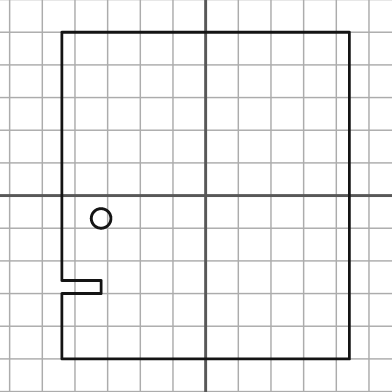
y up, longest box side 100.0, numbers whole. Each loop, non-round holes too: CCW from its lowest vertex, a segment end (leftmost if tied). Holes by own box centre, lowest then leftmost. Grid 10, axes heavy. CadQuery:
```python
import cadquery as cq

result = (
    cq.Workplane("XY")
    .moveTo(-44.0, -50.0)
    .lineTo(44.0, -50.0)
    .lineTo(44.0, 50.0)
    .lineTo(-44.0, 50.0)
    .lineTo(-44.0, -26.0)
    .lineTo(-32.0, -26.0)
    .lineTo(-32.0, -30.0)
    .lineTo(-44.0, -30.0)
    .close()
    .moveTo(-32.0, -7.0)
    .circle(3.0)
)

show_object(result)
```